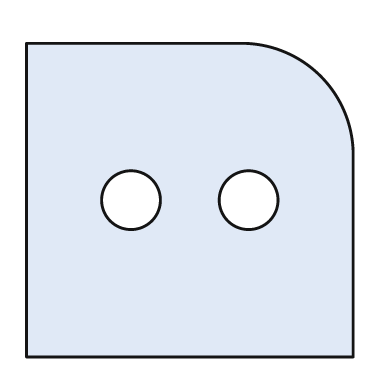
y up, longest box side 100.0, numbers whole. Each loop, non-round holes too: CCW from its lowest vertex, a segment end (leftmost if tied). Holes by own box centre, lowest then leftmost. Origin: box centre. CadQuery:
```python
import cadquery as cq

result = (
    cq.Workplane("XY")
    .moveTo(-50.0, -48.0)
    .lineTo(50.0, -48.0)
    .lineTo(50.0, 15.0)
    .threePointArc((40.0, 38.0), (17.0, 48.0))
    .lineTo(-50.0, 48.0)
    .close()
    .moveTo(-18.0, 0.0)
    .circle(9.0)
    .moveTo(18.0, 0.0)
    .circle(9.0)
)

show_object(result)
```